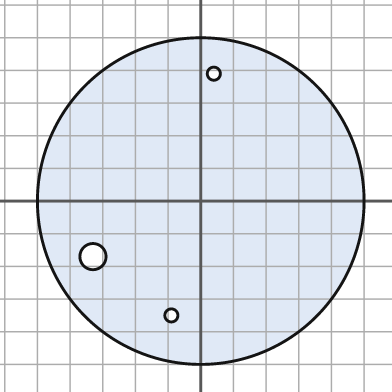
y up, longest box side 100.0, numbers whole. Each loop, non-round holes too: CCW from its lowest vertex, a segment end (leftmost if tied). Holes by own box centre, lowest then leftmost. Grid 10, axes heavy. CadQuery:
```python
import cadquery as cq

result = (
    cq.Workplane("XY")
    .moveTo(0.0, 0.0)
    .circle(50.0)
    .moveTo(-9.0, -35.0)
    .circle(2.0)
    .moveTo(-33.0, -17.0)
    .circle(4.0)
    .moveTo(4.0, 39.0)
    .circle(2.0)
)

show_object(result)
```